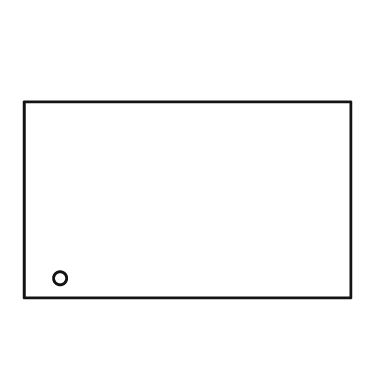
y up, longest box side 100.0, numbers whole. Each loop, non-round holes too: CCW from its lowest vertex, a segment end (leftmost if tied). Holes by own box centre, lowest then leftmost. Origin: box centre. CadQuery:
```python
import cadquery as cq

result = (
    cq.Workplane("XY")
    .moveTo(-50.0, -30.0)
    .lineTo(50.0, -30.0)
    .lineTo(50.0, 30.0)
    .lineTo(-50.0, 30.0)
    .close()
    .moveTo(-39.0, -24.0)
    .circle(2.0)
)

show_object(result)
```